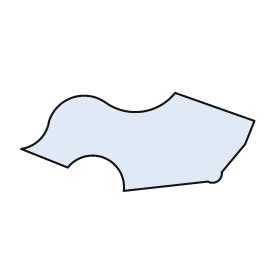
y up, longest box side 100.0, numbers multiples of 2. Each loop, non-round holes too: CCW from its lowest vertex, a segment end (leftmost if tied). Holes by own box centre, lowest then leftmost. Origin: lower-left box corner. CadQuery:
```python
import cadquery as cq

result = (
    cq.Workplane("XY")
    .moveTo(44.0, 0.0)
    .lineTo(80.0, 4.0)
    .threePointArc((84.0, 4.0), (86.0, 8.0))
    .lineTo(96.0, 20.0)
    .lineTo(100.0, 30.0)
    .lineTo(66.0, 42.0)
    .threePointArc((52.0, 34.0), (36.0, 38.0))
    .threePointArc((22.0, 40.0), (12.0, 30.0))
    .threePointArc((8.0, 22.0), (0.0, 18.0))
    .lineTo(20.0, 10.0)
    .threePointArc((36.0, 14.0), (44.0, 0.0))
    .close()
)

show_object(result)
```